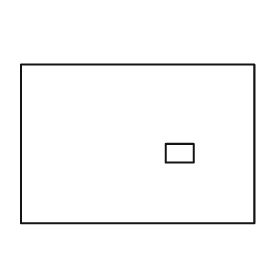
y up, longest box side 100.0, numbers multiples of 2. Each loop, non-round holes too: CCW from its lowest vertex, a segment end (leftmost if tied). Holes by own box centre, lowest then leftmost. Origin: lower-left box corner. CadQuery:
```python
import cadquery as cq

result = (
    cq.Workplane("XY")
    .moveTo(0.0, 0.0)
    .lineTo(100.0, 0.0)
    .lineTo(100.0, 68.0)
    .lineTo(0.0, 68.0)
    .close()
    .moveTo(62.0, 26.0)
    .lineTo(74.0, 26.0)
    .lineTo(74.0, 34.0)
    .lineTo(62.0, 34.0)
    .close()
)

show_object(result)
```